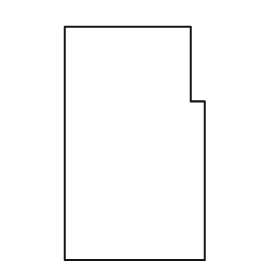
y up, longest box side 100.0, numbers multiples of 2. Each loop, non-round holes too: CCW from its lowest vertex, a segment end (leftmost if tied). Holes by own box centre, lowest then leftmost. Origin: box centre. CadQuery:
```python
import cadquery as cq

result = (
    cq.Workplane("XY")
    .moveTo(-30.0, -50.0)
    .lineTo(30.0, -50.0)
    .lineTo(30.0, 18.0)
    .lineTo(24.0, 18.0)
    .lineTo(24.0, 50.0)
    .lineTo(-30.0, 50.0)
    .close()
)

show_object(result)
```